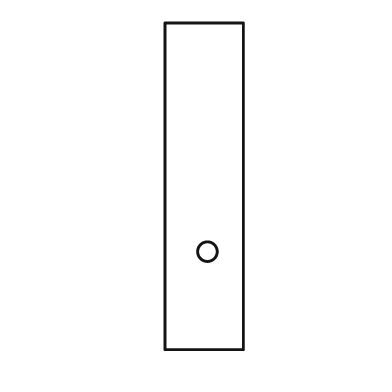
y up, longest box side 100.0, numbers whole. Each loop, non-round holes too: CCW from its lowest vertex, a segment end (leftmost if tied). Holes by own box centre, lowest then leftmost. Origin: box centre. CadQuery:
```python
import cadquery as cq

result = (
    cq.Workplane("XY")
    .moveTo(-12.0, -50.0)
    .lineTo(12.0, -50.0)
    .lineTo(12.0, 50.0)
    .lineTo(-12.0, 50.0)
    .close()
    .moveTo(1.0, -20.0)
    .circle(3.0)
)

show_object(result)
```